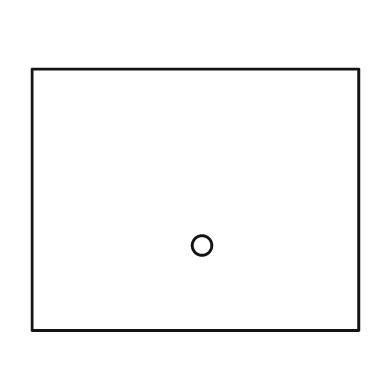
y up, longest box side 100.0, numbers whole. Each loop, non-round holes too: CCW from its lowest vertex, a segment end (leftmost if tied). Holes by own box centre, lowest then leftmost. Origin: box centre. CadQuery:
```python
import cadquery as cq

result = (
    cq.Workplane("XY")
    .moveTo(-50.0, -40.0)
    .lineTo(50.0, -40.0)
    .lineTo(50.0, 40.0)
    .lineTo(-50.0, 40.0)
    .close()
    .moveTo(2.0, -14.0)
    .circle(3.0)
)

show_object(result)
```